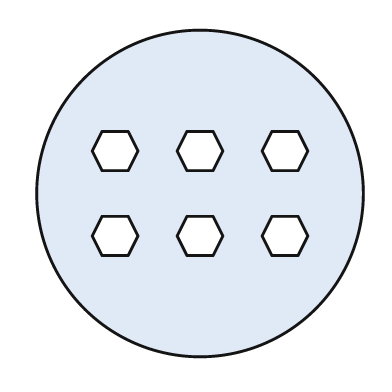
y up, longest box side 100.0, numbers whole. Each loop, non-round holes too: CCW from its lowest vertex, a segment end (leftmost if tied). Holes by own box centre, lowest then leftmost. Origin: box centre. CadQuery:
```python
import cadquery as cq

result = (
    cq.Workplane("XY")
    .moveTo(0.0, 0.0)
    .circle(50.0)
    .moveTo(-30.0, -19.0)
    .lineTo(-22.0, -19.0)
    .lineTo(-19.0, -13.0)
    .lineTo(-22.0, -7.0)
    .lineTo(-30.0, -7.0)
    .lineTo(-33.0, -13.0)
    .close()
    .moveTo(-4.0, -19.0)
    .lineTo(4.0, -19.0)
    .lineTo(7.0, -13.0)
    .lineTo(4.0, -7.0)
    .lineTo(-4.0, -7.0)
    .lineTo(-7.0, -13.0)
    .close()
    .moveTo(22.0, -19.0)
    .lineTo(30.0, -19.0)
    .lineTo(33.0, -13.0)
    .lineTo(30.0, -7.0)
    .lineTo(22.0, -7.0)
    .lineTo(19.0, -13.0)
    .close()
    .moveTo(-30.0, 7.0)
    .lineTo(-22.0, 7.0)
    .lineTo(-19.0, 13.0)
    .lineTo(-22.0, 19.0)
    .lineTo(-30.0, 19.0)
    .lineTo(-33.0, 13.0)
    .close()
    .moveTo(-4.0, 7.0)
    .lineTo(4.0, 7.0)
    .lineTo(7.0, 13.0)
    .lineTo(4.0, 19.0)
    .lineTo(-4.0, 19.0)
    .lineTo(-7.0, 13.0)
    .close()
    .moveTo(22.0, 7.0)
    .lineTo(30.0, 7.0)
    .lineTo(33.0, 13.0)
    .lineTo(30.0, 19.0)
    .lineTo(22.0, 19.0)
    .lineTo(19.0, 13.0)
    .close()
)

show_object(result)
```